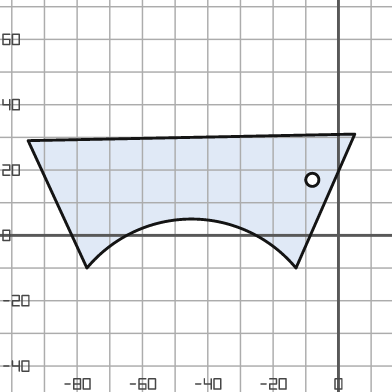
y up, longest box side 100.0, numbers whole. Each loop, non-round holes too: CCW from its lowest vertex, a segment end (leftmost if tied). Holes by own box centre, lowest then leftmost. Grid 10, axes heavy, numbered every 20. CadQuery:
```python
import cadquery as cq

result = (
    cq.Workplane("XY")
    .moveTo(-77.0, -10.0)
    .threePointArc((-45.0, 5.0), (-13.0, -10.0))
    .lineTo(5.0, 31.0)
    .lineTo(-95.0, 29.0)
    .close()
    .moveTo(-8.0, 17.0)
    .circle(2.0)
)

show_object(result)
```